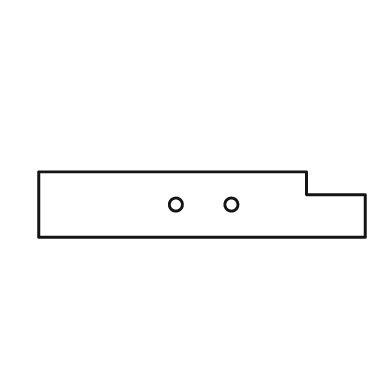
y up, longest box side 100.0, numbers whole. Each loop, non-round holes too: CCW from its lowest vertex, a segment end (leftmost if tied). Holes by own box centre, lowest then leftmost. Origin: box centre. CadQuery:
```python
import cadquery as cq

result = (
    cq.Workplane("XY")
    .moveTo(-50.0, -10.0)
    .lineTo(50.0, -10.0)
    .lineTo(50.0, 3.0)
    .lineTo(32.0, 3.0)
    .lineTo(32.0, 10.0)
    .lineTo(-50.0, 10.0)
    .close()
    .moveTo(-8.0, 0.0)
    .circle(2.0)
    .moveTo(9.0, 0.0)
    .circle(2.0)
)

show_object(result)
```